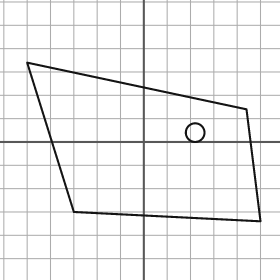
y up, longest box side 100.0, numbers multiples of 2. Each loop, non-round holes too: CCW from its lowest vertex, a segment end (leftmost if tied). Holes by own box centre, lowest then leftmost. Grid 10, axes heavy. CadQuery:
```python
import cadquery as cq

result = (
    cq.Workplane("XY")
    .moveTo(50.0, -34.0)
    .lineTo(44.0, 14.0)
    .lineTo(-50.0, 34.0)
    .lineTo(-30.0, -30.0)
    .close()
    .moveTo(22.0, 4.0)
    .circle(4.0)
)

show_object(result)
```